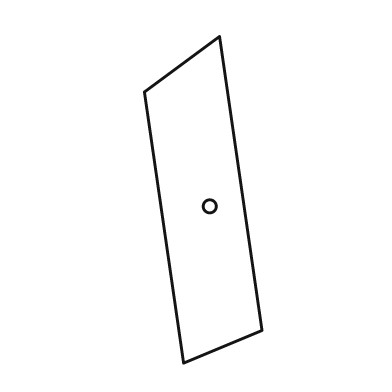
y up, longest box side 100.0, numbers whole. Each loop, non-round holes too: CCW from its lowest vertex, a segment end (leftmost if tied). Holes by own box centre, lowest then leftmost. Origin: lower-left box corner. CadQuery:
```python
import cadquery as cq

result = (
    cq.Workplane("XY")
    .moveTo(12.0, 0.0)
    .lineTo(36.0, 10.0)
    .lineTo(23.0, 100.0)
    .lineTo(0.0, 83.0)
    .close()
    .moveTo(20.0, 48.0)
    .circle(2.0)
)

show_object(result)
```